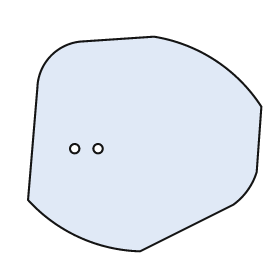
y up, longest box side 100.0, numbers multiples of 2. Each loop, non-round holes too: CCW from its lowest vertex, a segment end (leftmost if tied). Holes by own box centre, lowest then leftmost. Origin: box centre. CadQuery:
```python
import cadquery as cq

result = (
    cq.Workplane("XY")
    .moveTo(-2.0, -46.0)
    .lineTo(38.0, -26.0)
    .threePointArc((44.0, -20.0), (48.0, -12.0))
    .lineTo(50.0, 16.0)
    .threePointArc((30.0, 36.0), (4.0, 46.0))
    .lineTo(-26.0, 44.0)
    .threePointArc((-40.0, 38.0), (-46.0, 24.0))
    .lineTo(-50.0, -24.0)
    .threePointArc((-28.0, -40.0), (-2.0, -46.0))
    .close()
    .moveTo(-30.0, -2.0)
    .circle(2.0)
    .moveTo(-20.0, -2.0)
    .circle(2.0)
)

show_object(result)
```